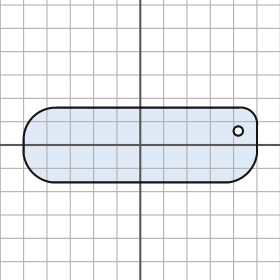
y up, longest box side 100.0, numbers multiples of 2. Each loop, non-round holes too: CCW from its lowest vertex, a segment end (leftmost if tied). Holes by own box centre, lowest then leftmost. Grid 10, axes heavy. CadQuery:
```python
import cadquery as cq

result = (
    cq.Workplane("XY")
    .moveTo(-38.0, -16.0)
    .lineTo(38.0, -16.0)
    .threePointArc((46.0, -12.0), (50.0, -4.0))
    .lineTo(50.0, 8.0)
    .threePointArc((48.0, 14.0), (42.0, 16.0))
    .lineTo(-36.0, 16.0)
    .threePointArc((-46.0, 12.0), (-50.0, 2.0))
    .lineTo(-50.0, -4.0)
    .threePointArc((-46.0, -12.0), (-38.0, -16.0))
    .close()
    .moveTo(42.0, 6.0)
    .circle(2.0)
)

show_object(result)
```